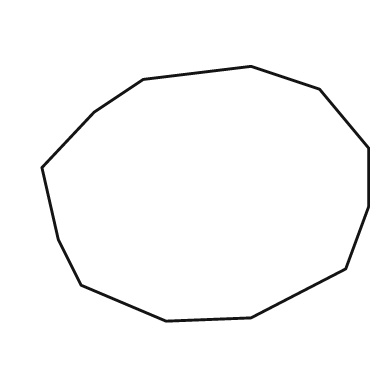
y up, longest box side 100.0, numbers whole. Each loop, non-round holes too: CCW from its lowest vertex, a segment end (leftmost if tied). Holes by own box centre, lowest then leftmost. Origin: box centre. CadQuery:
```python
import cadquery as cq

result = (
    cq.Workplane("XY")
    .moveTo(-12.0, -39.0)
    .lineTo(14.0, -38.0)
    .lineTo(43.0, -23.0)
    .lineTo(50.0, -4.0)
    .lineTo(50.0, 14.0)
    .lineTo(35.0, 32.0)
    .lineTo(14.0, 39.0)
    .lineTo(-19.0, 35.0)
    .lineTo(-34.0, 25.0)
    .lineTo(-50.0, 8.0)
    .lineTo(-45.0, -14.0)
    .lineTo(-38.0, -28.0)
    .close()
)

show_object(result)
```